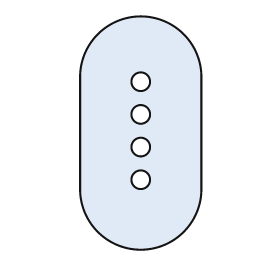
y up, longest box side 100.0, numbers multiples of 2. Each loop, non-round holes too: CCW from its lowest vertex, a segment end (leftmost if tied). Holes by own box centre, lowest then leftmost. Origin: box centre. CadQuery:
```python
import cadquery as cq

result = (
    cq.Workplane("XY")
    .moveTo(-26.0, -24.0)
    .threePointArc((0.0, -50.0), (26.0, -24.0))
    .lineTo(26.0, 24.0)
    .threePointArc((0.0, 50.0), (-26.0, 24.0))
    .close()
    .moveTo(0.0, -20.0)
    .circle(4.0)
    .moveTo(0.0, -6.0)
    .circle(4.0)
    .moveTo(0.0, 8.0)
    .circle(4.0)
    .moveTo(0.0, 22.0)
    .circle(4.0)
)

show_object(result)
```